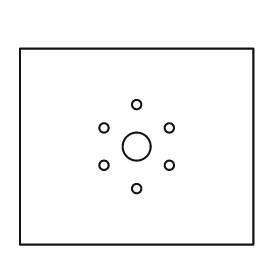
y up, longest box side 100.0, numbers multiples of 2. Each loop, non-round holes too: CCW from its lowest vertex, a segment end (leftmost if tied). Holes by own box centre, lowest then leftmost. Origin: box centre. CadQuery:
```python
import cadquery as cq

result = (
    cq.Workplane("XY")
    .moveTo(-50.0, -42.0)
    .lineTo(50.0, -42.0)
    .lineTo(50.0, 42.0)
    .lineTo(-50.0, 42.0)
    .close()
    .moveTo(0.0, -18.0)
    .circle(2.0)
    .moveTo(-14.0, -8.0)
    .circle(2.0)
    .moveTo(14.0, -8.0)
    .circle(2.0)
    .moveTo(0.0, 0.0)
    .circle(6.0)
    .moveTo(-14.0, 8.0)
    .circle(2.0)
    .moveTo(14.0, 8.0)
    .circle(2.0)
    .moveTo(0.0, 18.0)
    .circle(2.0)
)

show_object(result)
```